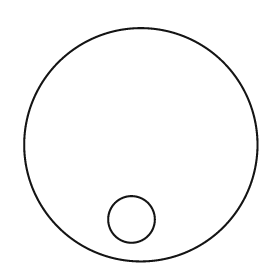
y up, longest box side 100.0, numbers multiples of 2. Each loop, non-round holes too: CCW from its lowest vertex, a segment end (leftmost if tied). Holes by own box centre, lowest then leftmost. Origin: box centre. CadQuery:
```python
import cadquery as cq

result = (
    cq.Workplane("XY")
    .moveTo(0.0, 0.0)
    .circle(50.0)
    .moveTo(-4.0, -32.0)
    .circle(10.0)
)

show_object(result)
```